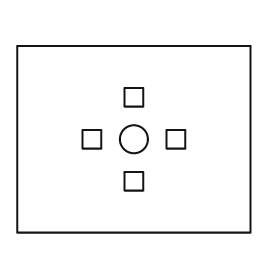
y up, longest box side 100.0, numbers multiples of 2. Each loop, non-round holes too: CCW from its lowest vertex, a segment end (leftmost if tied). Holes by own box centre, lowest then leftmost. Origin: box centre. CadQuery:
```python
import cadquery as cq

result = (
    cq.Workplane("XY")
    .moveTo(-50.0, -40.0)
    .lineTo(50.0, -40.0)
    .lineTo(50.0, 40.0)
    .lineTo(-50.0, 40.0)
    .close()
    .moveTo(-4.0, -22.0)
    .lineTo(4.0, -22.0)
    .lineTo(4.0, -14.0)
    .lineTo(-4.0, -14.0)
    .close()
    .moveTo(-22.0, -4.0)
    .lineTo(-14.0, -4.0)
    .lineTo(-14.0, 4.0)
    .lineTo(-22.0, 4.0)
    .close()
    .moveTo(0.0, 0.0)
    .circle(6.0)
    .moveTo(14.0, -4.0)
    .lineTo(22.0, -4.0)
    .lineTo(22.0, 4.0)
    .lineTo(14.0, 4.0)
    .close()
    .moveTo(-4.0, 14.0)
    .lineTo(4.0, 14.0)
    .lineTo(4.0, 22.0)
    .lineTo(-4.0, 22.0)
    .close()
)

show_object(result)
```